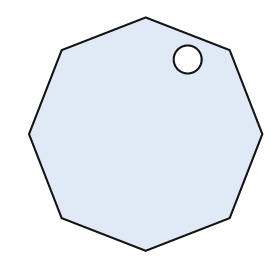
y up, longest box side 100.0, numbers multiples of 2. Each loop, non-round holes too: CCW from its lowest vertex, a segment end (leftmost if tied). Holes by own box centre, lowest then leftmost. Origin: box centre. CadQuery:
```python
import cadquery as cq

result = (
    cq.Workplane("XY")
    .moveTo(0.0, -50.0)
    .lineTo(36.0, -36.0)
    .lineTo(50.0, 0.0)
    .lineTo(36.0, 36.0)
    .lineTo(0.0, 50.0)
    .lineTo(-36.0, 36.0)
    .lineTo(-50.0, 0.0)
    .lineTo(-36.0, -36.0)
    .close()
    .moveTo(18.0, 32.0)
    .circle(6.0)
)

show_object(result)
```